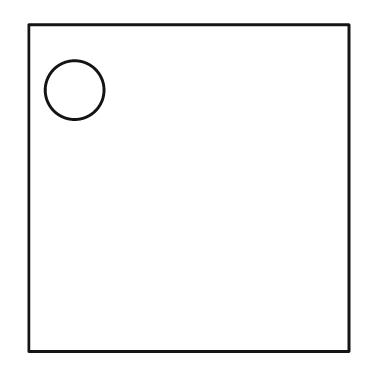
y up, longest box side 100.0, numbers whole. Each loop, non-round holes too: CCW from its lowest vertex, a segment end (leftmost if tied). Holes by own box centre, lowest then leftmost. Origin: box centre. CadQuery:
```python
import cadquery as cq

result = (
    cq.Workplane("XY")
    .moveTo(-49.0, -50.0)
    .lineTo(49.0, -50.0)
    .lineTo(49.0, 50.0)
    .lineTo(-49.0, 50.0)
    .close()
    .moveTo(-35.0, 30.0)
    .circle(9.0)
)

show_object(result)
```